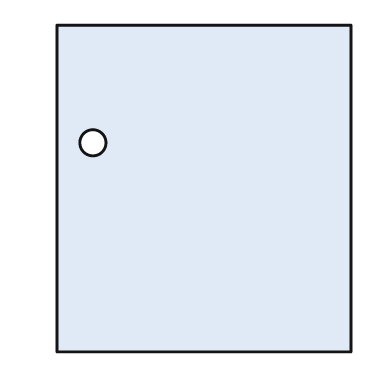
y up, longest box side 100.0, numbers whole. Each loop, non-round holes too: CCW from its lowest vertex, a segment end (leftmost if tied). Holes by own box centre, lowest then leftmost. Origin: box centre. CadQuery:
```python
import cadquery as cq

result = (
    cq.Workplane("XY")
    .moveTo(-45.0, -50.0)
    .lineTo(45.0, -50.0)
    .lineTo(45.0, 50.0)
    .lineTo(-45.0, 50.0)
    .close()
    .moveTo(-34.0, 14.0)
    .circle(4.0)
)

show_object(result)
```